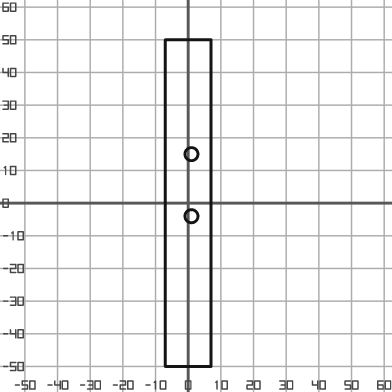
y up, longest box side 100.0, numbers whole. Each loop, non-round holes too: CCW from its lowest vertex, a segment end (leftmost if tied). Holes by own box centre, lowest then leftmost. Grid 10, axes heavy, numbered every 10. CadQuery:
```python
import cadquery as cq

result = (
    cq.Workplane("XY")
    .moveTo(-7.0, -50.0)
    .lineTo(7.0, -50.0)
    .lineTo(7.0, 50.0)
    .lineTo(-7.0, 50.0)
    .close()
    .moveTo(1.0, -4.0)
    .circle(2.0)
    .moveTo(1.0, 15.0)
    .circle(2.0)
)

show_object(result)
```